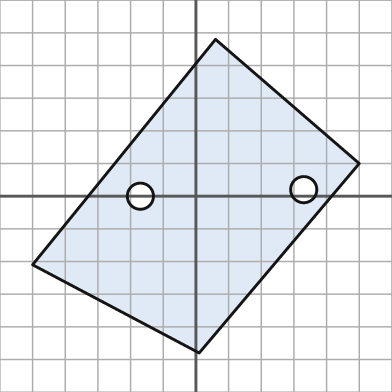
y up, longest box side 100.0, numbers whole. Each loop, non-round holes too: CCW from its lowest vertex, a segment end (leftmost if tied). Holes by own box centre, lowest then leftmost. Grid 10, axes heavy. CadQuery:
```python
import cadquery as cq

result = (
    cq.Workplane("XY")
    .moveTo(1.0, -48.0)
    .lineTo(50.0, 10.0)
    .lineTo(6.0, 48.0)
    .lineTo(-50.0, -21.0)
    .close()
    .moveTo(-17.0, 0.0)
    .circle(4.0)
    .moveTo(33.0, 2.0)
    .circle(4.0)
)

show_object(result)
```